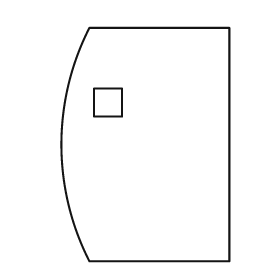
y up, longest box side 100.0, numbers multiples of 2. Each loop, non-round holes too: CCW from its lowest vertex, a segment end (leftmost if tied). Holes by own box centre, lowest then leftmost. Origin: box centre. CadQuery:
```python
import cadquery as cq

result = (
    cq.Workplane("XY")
    .moveTo(-24.0, -50.0)
    .lineTo(36.0, -50.0)
    .lineTo(36.0, 50.0)
    .lineTo(-24.0, 50.0)
    .threePointArc((-36.0, 0.0), (-24.0, -50.0))
    .close()
    .moveTo(-22.0, 12.0)
    .lineTo(-10.0, 12.0)
    .lineTo(-10.0, 24.0)
    .lineTo(-22.0, 24.0)
    .close()
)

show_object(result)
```